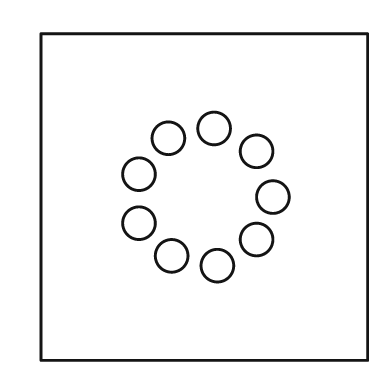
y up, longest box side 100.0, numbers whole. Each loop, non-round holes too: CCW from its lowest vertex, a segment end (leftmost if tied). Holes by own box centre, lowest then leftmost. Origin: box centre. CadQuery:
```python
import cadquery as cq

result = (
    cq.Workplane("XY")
    .moveTo(-50.0, -50.0)
    .lineTo(50.0, -50.0)
    .lineTo(50.0, 50.0)
    .lineTo(-50.0, 50.0)
    .close()
    .moveTo(4.0, -21.0)
    .circle(5.0)
    .moveTo(-10.0, -18.0)
    .circle(5.0)
    .moveTo(16.0, -13.0)
    .circle(5.0)
    .moveTo(-20.0, -8.0)
    .circle(5.0)
    .moveTo(21.0, 0.0)
    .circle(5.0)
    .moveTo(-20.0, 7.0)
    .circle(5.0)
    .moveTo(16.0, 14.0)
    .circle(5.0)
    .moveTo(-11.0, 18.0)
    .circle(5.0)
    .moveTo(3.0, 21.0)
    .circle(5.0)
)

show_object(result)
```